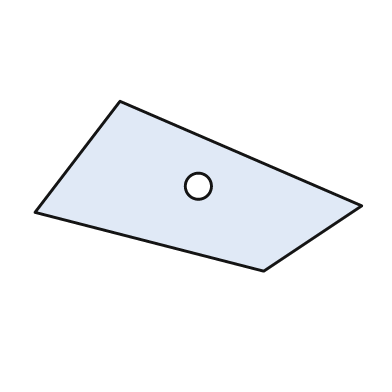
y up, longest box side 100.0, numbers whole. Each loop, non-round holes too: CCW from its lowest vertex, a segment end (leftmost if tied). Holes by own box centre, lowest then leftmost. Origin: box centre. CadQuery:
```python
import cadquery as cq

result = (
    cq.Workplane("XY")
    .moveTo(20.0, -26.0)
    .lineTo(50.0, -6.0)
    .lineTo(-24.0, 26.0)
    .lineTo(-50.0, -8.0)
    .close()
    .moveTo(0.0, 0.0)
    .circle(4.0)
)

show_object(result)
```